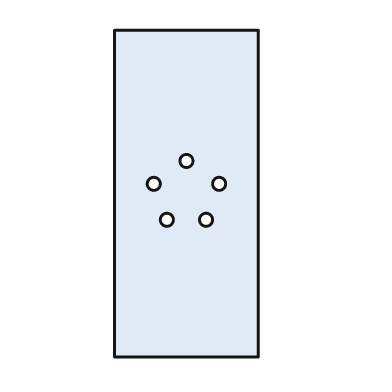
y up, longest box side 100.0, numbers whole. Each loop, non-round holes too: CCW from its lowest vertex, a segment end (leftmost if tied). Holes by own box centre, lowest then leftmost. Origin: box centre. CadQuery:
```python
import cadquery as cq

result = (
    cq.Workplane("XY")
    .moveTo(-22.0, -50.0)
    .lineTo(22.0, -50.0)
    .lineTo(22.0, 50.0)
    .lineTo(-22.0, 50.0)
    .close()
    .moveTo(-6.0, -8.0)
    .circle(2.0)
    .moveTo(6.0, -8.0)
    .circle(2.0)
    .moveTo(-10.0, 3.0)
    .circle(2.0)
    .moveTo(10.0, 3.0)
    .circle(2.0)
    .moveTo(0.0, 10.0)
    .circle(2.0)
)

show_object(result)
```